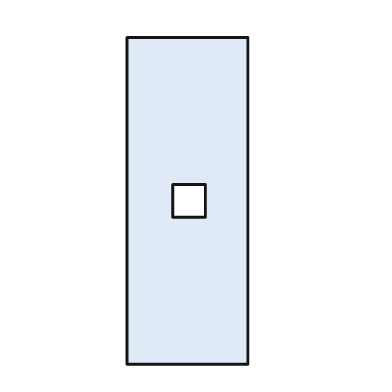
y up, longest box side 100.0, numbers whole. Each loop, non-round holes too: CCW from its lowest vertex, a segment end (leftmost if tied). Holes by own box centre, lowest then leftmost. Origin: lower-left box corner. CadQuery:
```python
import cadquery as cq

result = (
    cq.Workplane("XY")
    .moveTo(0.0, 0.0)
    .lineTo(37.0, 0.0)
    .lineTo(37.0, 100.0)
    .lineTo(0.0, 100.0)
    .close()
    .moveTo(14.0, 45.0)
    .lineTo(24.0, 45.0)
    .lineTo(24.0, 55.0)
    .lineTo(14.0, 55.0)
    .close()
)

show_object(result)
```